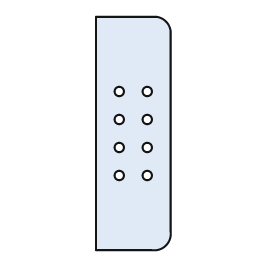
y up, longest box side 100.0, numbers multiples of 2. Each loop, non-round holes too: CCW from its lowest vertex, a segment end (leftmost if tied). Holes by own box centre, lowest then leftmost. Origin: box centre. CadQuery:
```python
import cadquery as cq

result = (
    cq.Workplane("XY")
    .moveTo(-16.0, -50.0)
    .lineTo(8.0, -50.0)
    .threePointArc((14.0, -48.0), (16.0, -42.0))
    .lineTo(16.0, 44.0)
    .threePointArc((14.0, 48.0), (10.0, 50.0))
    .lineTo(-16.0, 50.0)
    .close()
    .moveTo(-6.0, -18.0)
    .circle(2.0)
    .moveTo(6.0, -18.0)
    .circle(2.0)
    .moveTo(-6.0, -6.0)
    .circle(2.0)
    .moveTo(6.0, -6.0)
    .circle(2.0)
    .moveTo(-6.0, 6.0)
    .circle(2.0)
    .moveTo(6.0, 6.0)
    .circle(2.0)
    .moveTo(-6.0, 18.0)
    .circle(2.0)
    .moveTo(6.0, 18.0)
    .circle(2.0)
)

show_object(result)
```